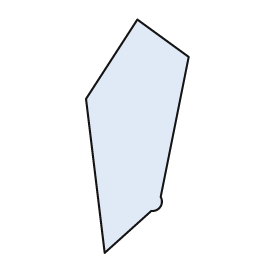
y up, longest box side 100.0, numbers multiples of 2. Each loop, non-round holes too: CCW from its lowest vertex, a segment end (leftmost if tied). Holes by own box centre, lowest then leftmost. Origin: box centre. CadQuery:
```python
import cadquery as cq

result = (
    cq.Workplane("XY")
    .moveTo(-14.0, -50.0)
    .lineTo(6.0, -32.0)
    .threePointArc((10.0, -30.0), (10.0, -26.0))
    .lineTo(22.0, 34.0)
    .lineTo(0.0, 50.0)
    .lineTo(-22.0, 16.0)
    .close()
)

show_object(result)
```